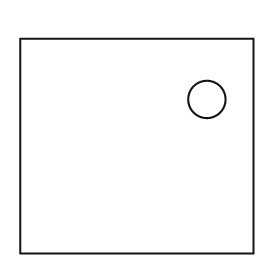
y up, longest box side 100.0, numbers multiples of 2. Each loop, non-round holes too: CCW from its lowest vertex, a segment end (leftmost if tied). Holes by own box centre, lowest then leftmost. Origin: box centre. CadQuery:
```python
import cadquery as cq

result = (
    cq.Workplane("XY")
    .moveTo(-50.0, -46.0)
    .lineTo(50.0, -46.0)
    .lineTo(50.0, 46.0)
    .lineTo(-50.0, 46.0)
    .close()
    .moveTo(30.0, 20.0)
    .circle(8.0)
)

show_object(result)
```